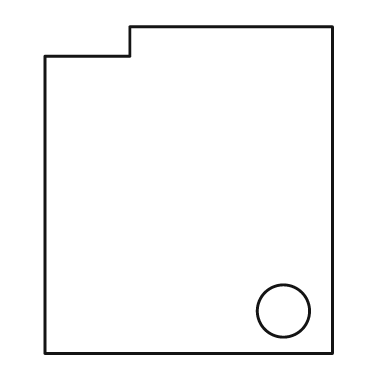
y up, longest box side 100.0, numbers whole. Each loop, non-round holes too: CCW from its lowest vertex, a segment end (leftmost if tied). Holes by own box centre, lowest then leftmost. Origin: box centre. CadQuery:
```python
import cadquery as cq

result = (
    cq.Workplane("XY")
    .moveTo(-44.0, -50.0)
    .lineTo(44.0, -50.0)
    .lineTo(44.0, 50.0)
    .lineTo(-18.0, 50.0)
    .lineTo(-18.0, 41.0)
    .lineTo(-44.0, 41.0)
    .close()
    .moveTo(29.0, -37.0)
    .circle(8.0)
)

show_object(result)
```